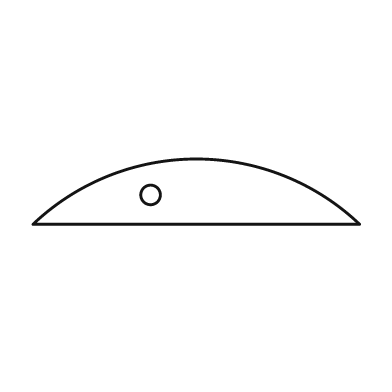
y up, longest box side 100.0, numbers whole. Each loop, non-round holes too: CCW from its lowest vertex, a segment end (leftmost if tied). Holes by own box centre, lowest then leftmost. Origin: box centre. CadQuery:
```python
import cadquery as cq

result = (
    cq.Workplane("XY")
    .moveTo(-50.0, -10.0)
    .lineTo(50.0, -10.0)
    .threePointArc((0.0, 10.0), (-50.0, -10.0))
    .close()
    .moveTo(-14.0, -1.0)
    .circle(3.0)
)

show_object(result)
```